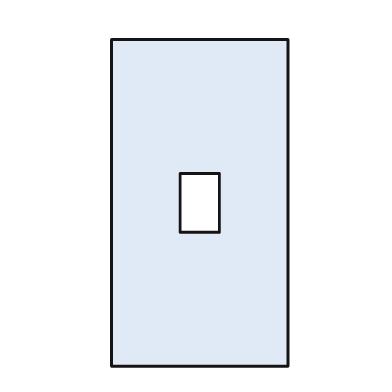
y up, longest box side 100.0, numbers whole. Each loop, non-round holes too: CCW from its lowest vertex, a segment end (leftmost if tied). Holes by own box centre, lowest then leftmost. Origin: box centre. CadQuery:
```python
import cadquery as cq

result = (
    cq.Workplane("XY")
    .moveTo(-27.0, -50.0)
    .lineTo(27.0, -50.0)
    .lineTo(27.0, 50.0)
    .lineTo(-27.0, 50.0)
    .close()
    .moveTo(-6.0, -9.0)
    .lineTo(6.0, -9.0)
    .lineTo(6.0, 9.0)
    .lineTo(-6.0, 9.0)
    .close()
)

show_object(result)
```